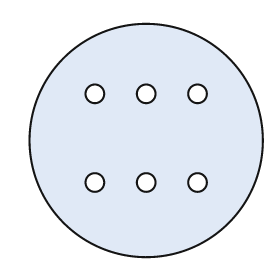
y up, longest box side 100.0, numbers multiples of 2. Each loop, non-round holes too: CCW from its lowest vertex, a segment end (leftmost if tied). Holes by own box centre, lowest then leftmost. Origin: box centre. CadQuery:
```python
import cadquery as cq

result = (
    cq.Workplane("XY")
    .moveTo(0.0, 0.0)
    .circle(50.0)
    .moveTo(-22.0, -18.0)
    .circle(4.0)
    .moveTo(0.0, -18.0)
    .circle(4.0)
    .moveTo(22.0, -18.0)
    .circle(4.0)
    .moveTo(-22.0, 20.0)
    .circle(4.0)
    .moveTo(0.0, 20.0)
    .circle(4.0)
    .moveTo(22.0, 20.0)
    .circle(4.0)
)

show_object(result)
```